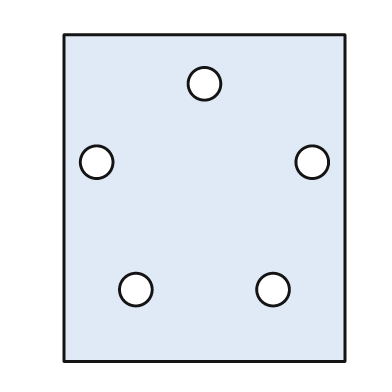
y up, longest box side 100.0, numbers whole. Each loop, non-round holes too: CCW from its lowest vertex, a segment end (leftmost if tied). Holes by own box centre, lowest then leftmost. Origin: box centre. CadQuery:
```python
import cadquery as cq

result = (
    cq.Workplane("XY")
    .moveTo(-43.0, -50.0)
    .lineTo(43.0, -50.0)
    .lineTo(43.0, 50.0)
    .lineTo(-43.0, 50.0)
    .close()
    .moveTo(-21.0, -28.0)
    .circle(5.0)
    .moveTo(21.0, -28.0)
    .circle(5.0)
    .moveTo(-33.0, 11.0)
    .circle(5.0)
    .moveTo(33.0, 11.0)
    .circle(5.0)
    .moveTo(0.0, 35.0)
    .circle(5.0)
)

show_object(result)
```